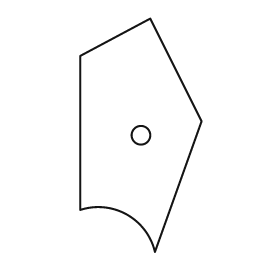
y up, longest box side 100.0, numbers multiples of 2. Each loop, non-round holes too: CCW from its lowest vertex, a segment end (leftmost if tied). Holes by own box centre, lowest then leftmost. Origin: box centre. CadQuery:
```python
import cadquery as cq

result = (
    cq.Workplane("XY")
    .moveTo(6.0, -50.0)
    .lineTo(26.0, 6.0)
    .lineTo(4.0, 50.0)
    .lineTo(-26.0, 34.0)
    .lineTo(-26.0, -32.0)
    .threePointArc((-6.0, -34.0), (6.0, -50.0))
    .close()
    .moveTo(0.0, 0.0)
    .circle(4.0)
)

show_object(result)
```